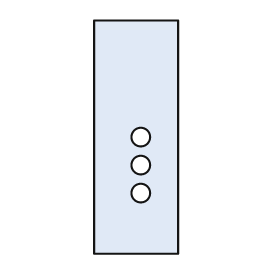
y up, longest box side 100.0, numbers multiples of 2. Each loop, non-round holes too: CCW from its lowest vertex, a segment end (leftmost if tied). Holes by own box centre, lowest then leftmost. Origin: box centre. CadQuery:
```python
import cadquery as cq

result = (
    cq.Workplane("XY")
    .moveTo(-18.0, -50.0)
    .lineTo(18.0, -50.0)
    .lineTo(18.0, 50.0)
    .lineTo(-18.0, 50.0)
    .close()
    .moveTo(2.0, -24.0)
    .circle(4.0)
    .moveTo(2.0, -12.0)
    .circle(4.0)
    .moveTo(2.0, 0.0)
    .circle(4.0)
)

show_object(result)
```